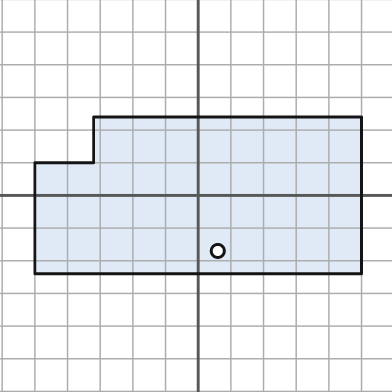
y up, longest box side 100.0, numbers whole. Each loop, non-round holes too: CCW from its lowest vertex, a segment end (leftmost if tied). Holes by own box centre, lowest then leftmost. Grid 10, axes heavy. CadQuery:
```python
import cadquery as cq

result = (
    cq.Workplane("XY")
    .moveTo(-50.0, -24.0)
    .lineTo(50.0, -24.0)
    .lineTo(50.0, 24.0)
    .lineTo(-32.0, 24.0)
    .lineTo(-32.0, 10.0)
    .lineTo(-50.0, 10.0)
    .close()
    .moveTo(6.0, -17.0)
    .circle(2.0)
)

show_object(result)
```